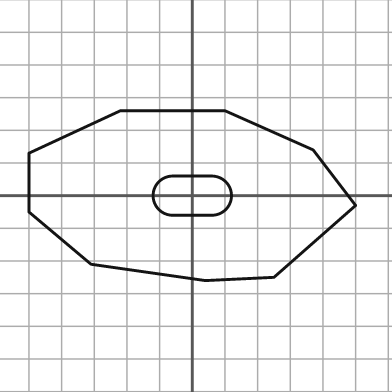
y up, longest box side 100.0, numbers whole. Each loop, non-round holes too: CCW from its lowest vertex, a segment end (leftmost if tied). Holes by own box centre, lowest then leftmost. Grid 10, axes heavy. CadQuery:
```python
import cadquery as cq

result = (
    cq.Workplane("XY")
    .moveTo(4.0, -26.0)
    .lineTo(25.0, -25.0)
    .lineTo(50.0, -3.0)
    .lineTo(37.0, 14.0)
    .lineTo(10.0, 26.0)
    .lineTo(-22.0, 26.0)
    .lineTo(-50.0, 13.0)
    .lineTo(-50.0, -5.0)
    .lineTo(-31.0, -21.0)
    .close()
    .moveTo(-6.0, -6.0)
    .lineTo(6.0, -6.0)
    .threePointArc((12.0, 0.0), (6.0, 6.0))
    .lineTo(-6.0, 6.0)
    .threePointArc((-12.0, 0.0), (-6.0, -6.0))
    .close()
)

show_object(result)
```